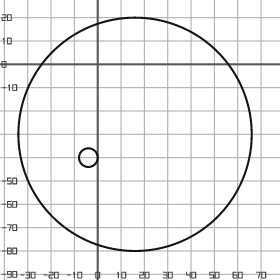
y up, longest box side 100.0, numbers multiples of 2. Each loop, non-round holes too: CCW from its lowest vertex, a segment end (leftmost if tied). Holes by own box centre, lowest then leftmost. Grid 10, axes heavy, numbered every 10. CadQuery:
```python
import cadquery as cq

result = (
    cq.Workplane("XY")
    .moveTo(16.0, -30.0)
    .circle(50.0)
    .moveTo(-4.0, -40.0)
    .circle(4.0)
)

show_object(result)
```